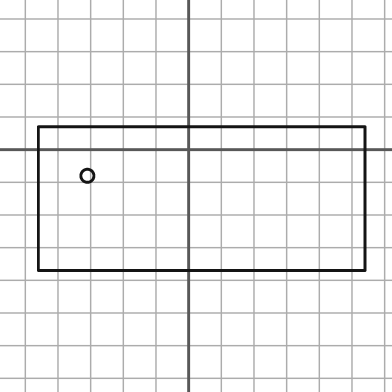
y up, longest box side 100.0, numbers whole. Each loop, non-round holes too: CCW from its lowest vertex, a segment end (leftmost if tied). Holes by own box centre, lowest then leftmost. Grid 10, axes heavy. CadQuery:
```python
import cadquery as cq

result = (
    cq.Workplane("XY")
    .moveTo(-46.0, -37.0)
    .lineTo(54.0, -37.0)
    .lineTo(54.0, 7.0)
    .lineTo(-46.0, 7.0)
    .close()
    .moveTo(-31.0, -8.0)
    .circle(2.0)
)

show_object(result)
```